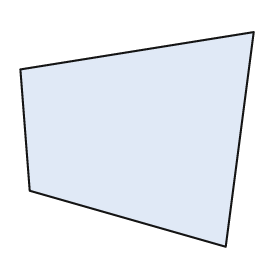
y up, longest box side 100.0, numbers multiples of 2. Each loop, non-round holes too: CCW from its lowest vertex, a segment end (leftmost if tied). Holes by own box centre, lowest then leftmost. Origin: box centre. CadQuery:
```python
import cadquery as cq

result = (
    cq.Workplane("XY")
    .moveTo(38.0, -46.0)
    .lineTo(50.0, 46.0)
    .lineTo(-50.0, 30.0)
    .lineTo(-46.0, -22.0)
    .close()
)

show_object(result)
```